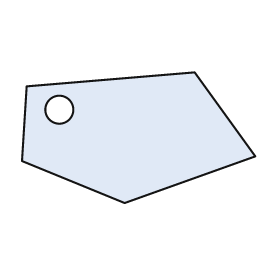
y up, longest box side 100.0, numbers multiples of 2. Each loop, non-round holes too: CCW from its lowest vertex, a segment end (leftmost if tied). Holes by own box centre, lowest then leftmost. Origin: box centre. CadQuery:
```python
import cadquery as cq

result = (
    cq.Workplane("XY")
    .moveTo(-6.0, -28.0)
    .lineTo(50.0, -8.0)
    .lineTo(24.0, 28.0)
    .lineTo(-48.0, 22.0)
    .lineTo(-50.0, -10.0)
    .close()
    .moveTo(-34.0, 12.0)
    .circle(6.0)
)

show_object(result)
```